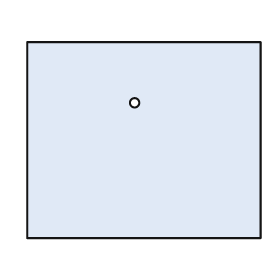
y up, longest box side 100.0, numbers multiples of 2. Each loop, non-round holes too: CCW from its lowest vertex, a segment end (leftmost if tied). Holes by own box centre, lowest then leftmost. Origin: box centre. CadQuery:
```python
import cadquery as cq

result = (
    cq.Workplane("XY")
    .moveTo(-50.0, -42.0)
    .lineTo(50.0, -42.0)
    .lineTo(50.0, 42.0)
    .lineTo(-50.0, 42.0)
    .close()
    .moveTo(-4.0, 16.0)
    .circle(2.0)
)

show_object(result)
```